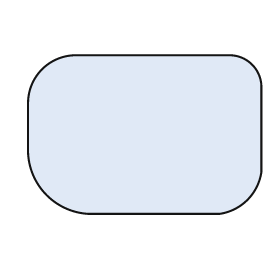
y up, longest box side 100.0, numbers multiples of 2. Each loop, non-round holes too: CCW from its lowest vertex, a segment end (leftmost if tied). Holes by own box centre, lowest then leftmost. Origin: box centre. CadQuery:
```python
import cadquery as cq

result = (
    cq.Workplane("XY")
    .moveTo(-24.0, -34.0)
    .lineTo(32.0, -34.0)
    .threePointArc((44.0, -28.0), (50.0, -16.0))
    .lineTo(50.0, 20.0)
    .threePointArc((46.0, 30.0), (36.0, 34.0))
    .lineTo(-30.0, 34.0)
    .threePointArc((-44.0, 28.0), (-50.0, 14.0))
    .lineTo(-50.0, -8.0)
    .threePointArc((-42.0, -26.0), (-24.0, -34.0))
    .close()
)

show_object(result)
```